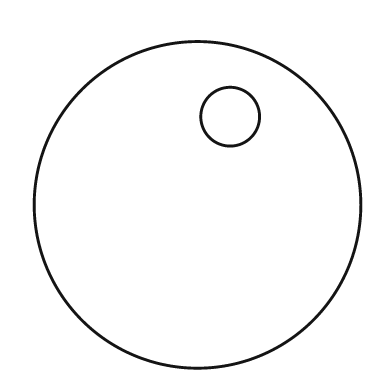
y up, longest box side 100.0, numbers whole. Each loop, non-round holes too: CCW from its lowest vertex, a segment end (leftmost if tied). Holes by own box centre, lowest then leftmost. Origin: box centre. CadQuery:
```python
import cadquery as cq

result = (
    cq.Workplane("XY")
    .moveTo(0.0, 0.0)
    .circle(50.0)
    .moveTo(10.0, 27.0)
    .circle(9.0)
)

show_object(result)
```